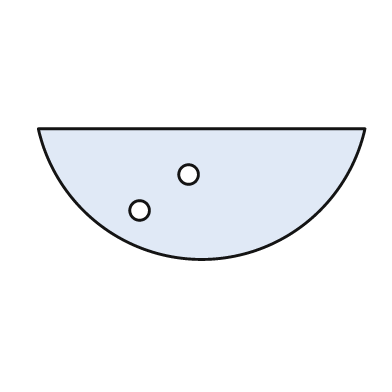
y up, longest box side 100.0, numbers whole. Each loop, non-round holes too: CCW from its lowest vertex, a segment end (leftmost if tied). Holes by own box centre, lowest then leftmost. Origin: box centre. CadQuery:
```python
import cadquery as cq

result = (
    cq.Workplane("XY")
    .moveTo(-50.0, 20.0)
    .threePointArc((0.0, -20.0), (50.0, 20.0))
    .close()
    .moveTo(-19.0, -5.0)
    .circle(3.0)
    .moveTo(-4.0, 6.0)
    .circle(3.0)
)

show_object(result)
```